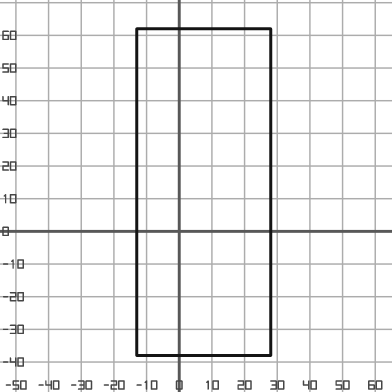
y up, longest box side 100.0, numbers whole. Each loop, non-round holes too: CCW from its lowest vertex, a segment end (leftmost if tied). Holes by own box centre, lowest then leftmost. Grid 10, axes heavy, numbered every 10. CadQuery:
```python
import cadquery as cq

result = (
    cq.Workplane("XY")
    .moveTo(-13.0, -38.0)
    .lineTo(28.0, -38.0)
    .lineTo(28.0, 62.0)
    .lineTo(-13.0, 62.0)
    .close()
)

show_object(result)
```